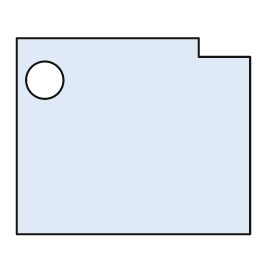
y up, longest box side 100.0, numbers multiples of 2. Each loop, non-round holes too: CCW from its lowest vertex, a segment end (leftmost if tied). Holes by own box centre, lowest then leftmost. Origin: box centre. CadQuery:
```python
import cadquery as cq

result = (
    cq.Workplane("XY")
    .moveTo(-50.0, -42.0)
    .lineTo(50.0, -42.0)
    .lineTo(50.0, 34.0)
    .lineTo(28.0, 34.0)
    .lineTo(28.0, 42.0)
    .lineTo(-50.0, 42.0)
    .close()
    .moveTo(-38.0, 24.0)
    .circle(8.0)
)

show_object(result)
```